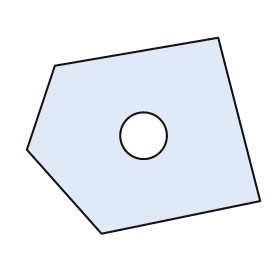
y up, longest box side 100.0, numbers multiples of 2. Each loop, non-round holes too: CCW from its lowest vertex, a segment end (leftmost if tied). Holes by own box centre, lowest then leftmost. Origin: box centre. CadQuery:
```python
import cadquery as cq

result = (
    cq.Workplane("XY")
    .moveTo(-18.0, -42.0)
    .lineTo(50.0, -28.0)
    .lineTo(32.0, 42.0)
    .lineTo(-38.0, 30.0)
    .lineTo(-50.0, -6.0)
    .close()
    .moveTo(0.0, 0.0)
    .circle(10.0)
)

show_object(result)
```